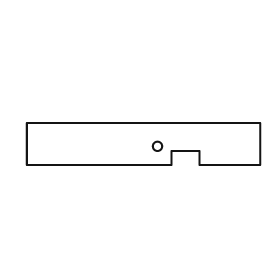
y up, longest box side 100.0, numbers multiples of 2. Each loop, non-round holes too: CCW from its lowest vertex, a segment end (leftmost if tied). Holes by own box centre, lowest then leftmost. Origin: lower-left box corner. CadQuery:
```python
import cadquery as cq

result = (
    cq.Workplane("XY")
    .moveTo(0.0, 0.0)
    .lineTo(62.0, 0.0)
    .lineTo(62.0, 6.0)
    .lineTo(74.0, 6.0)
    .lineTo(74.0, 0.0)
    .lineTo(100.0, 0.0)
    .lineTo(100.0, 18.0)
    .lineTo(0.0, 18.0)
    .close()
    .moveTo(56.0, 8.0)
    .circle(2.0)
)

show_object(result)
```